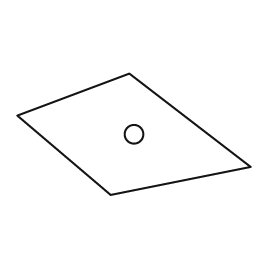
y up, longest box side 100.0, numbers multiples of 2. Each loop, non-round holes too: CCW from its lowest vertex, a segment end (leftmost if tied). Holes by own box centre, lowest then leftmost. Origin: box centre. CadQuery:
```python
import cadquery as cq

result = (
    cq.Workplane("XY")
    .moveTo(-10.0, -26.0)
    .lineTo(50.0, -14.0)
    .lineTo(-2.0, 26.0)
    .lineTo(-50.0, 8.0)
    .close()
    .moveTo(0.0, 0.0)
    .circle(4.0)
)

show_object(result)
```